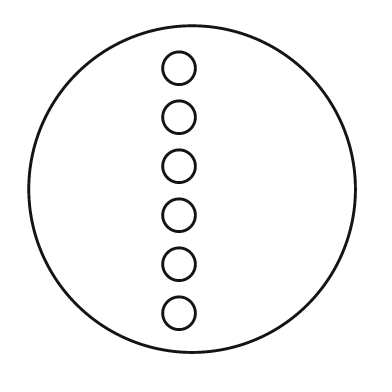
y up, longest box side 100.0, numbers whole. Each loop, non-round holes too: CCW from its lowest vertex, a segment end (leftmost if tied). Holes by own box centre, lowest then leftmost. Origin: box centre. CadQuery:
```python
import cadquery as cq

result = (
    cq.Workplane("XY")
    .moveTo(0.0, 0.0)
    .circle(50.0)
    .moveTo(-4.0, -38.0)
    .circle(5.0)
    .moveTo(-4.0, -23.0)
    .circle(5.0)
    .moveTo(-4.0, -8.0)
    .circle(5.0)
    .moveTo(-4.0, 7.0)
    .circle(5.0)
    .moveTo(-4.0, 22.0)
    .circle(5.0)
    .moveTo(-4.0, 37.0)
    .circle(5.0)
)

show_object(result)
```